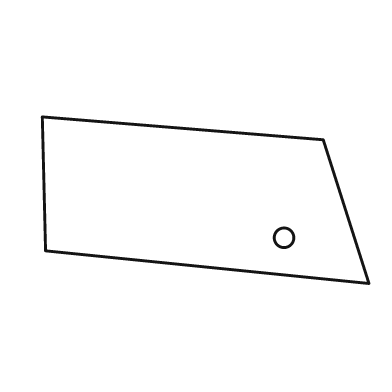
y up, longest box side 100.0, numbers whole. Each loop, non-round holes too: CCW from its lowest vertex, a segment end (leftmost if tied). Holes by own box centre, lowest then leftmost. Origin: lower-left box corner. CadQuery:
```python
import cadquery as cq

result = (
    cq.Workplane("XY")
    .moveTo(100.0, 0.0)
    .lineTo(86.0, 44.0)
    .lineTo(0.0, 51.0)
    .lineTo(1.0, 10.0)
    .close()
    .moveTo(74.0, 14.0)
    .circle(3.0)
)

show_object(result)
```